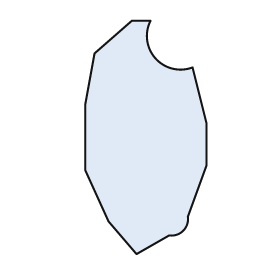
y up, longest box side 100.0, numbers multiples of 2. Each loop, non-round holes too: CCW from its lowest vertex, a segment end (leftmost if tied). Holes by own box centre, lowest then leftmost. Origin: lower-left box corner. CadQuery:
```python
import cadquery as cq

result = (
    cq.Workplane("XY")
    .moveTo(22.0, 0.0)
    .lineTo(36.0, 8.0)
    .threePointArc((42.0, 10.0), (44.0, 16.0))
    .lineTo(52.0, 38.0)
    .lineTo(52.0, 56.0)
    .lineTo(46.0, 80.0)
    .threePointArc((30.0, 84.0), (28.0, 100.0))
    .lineTo(20.0, 100.0)
    .lineTo(4.0, 86.0)
    .lineTo(0.0, 64.0)
    .lineTo(0.0, 36.0)
    .lineTo(10.0, 14.0)
    .close()
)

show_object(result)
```